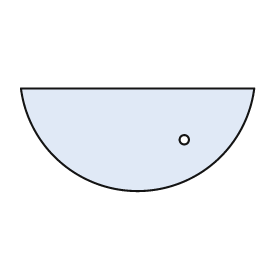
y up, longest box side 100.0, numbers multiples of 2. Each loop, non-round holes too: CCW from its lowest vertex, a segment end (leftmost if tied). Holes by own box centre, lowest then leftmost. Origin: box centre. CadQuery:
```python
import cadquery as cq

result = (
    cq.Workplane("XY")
    .moveTo(-50.0, 22.0)
    .threePointArc((0.0, -22.0), (50.0, 22.0))
    .close()
    .moveTo(20.0, 0.0)
    .circle(2.0)
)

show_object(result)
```